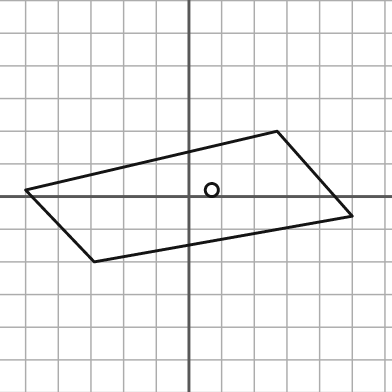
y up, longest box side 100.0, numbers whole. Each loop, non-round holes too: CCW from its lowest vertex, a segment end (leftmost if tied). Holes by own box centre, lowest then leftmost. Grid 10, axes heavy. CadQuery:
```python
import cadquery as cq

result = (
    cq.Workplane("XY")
    .moveTo(-29.0, -20.0)
    .lineTo(50.0, -6.0)
    .lineTo(27.0, 20.0)
    .lineTo(-50.0, 2.0)
    .close()
    .moveTo(7.0, 2.0)
    .circle(2.0)
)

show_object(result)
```